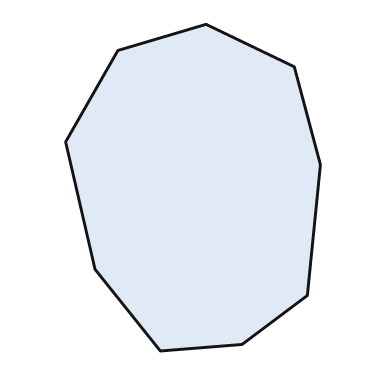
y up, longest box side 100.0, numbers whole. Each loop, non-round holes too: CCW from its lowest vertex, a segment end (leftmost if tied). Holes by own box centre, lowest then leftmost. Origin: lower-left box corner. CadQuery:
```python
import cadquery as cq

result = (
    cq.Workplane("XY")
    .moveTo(29.0, 0.0)
    .lineTo(54.0, 2.0)
    .lineTo(74.0, 17.0)
    .lineTo(78.0, 57.0)
    .lineTo(70.0, 87.0)
    .lineTo(43.0, 100.0)
    .lineTo(16.0, 92.0)
    .lineTo(0.0, 64.0)
    .lineTo(9.0, 25.0)
    .close()
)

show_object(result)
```